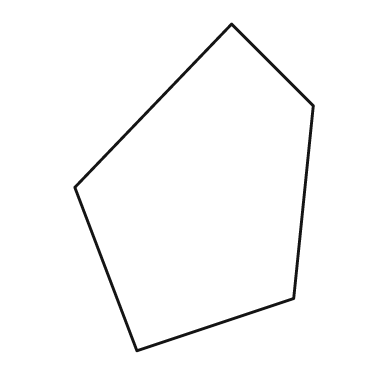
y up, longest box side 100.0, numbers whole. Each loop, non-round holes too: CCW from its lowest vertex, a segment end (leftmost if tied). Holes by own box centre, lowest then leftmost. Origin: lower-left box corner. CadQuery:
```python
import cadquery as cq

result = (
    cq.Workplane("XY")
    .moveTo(19.0, 0.0)
    .lineTo(67.0, 16.0)
    .lineTo(73.0, 75.0)
    .lineTo(48.0, 100.0)
    .lineTo(0.0, 50.0)
    .close()
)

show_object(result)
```